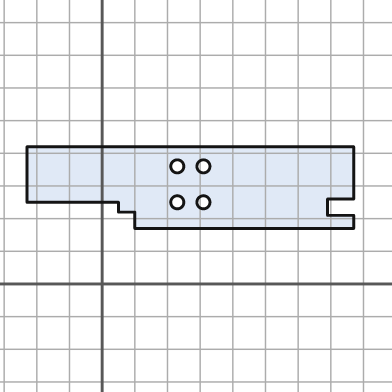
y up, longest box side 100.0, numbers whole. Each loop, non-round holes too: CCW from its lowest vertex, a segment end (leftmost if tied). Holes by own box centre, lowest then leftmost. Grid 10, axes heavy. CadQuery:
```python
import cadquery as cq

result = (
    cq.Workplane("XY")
    .moveTo(10.0, 17.0)
    .lineTo(77.0, 17.0)
    .lineTo(77.0, 21.0)
    .lineTo(69.0, 21.0)
    .lineTo(69.0, 26.0)
    .lineTo(77.0, 26.0)
    .lineTo(77.0, 42.0)
    .lineTo(-23.0, 42.0)
    .lineTo(-23.0, 25.0)
    .lineTo(5.0, 25.0)
    .lineTo(5.0, 22.0)
    .lineTo(10.0, 22.0)
    .close()
    .moveTo(23.0, 25.0)
    .circle(2.0)
    .moveTo(31.0, 25.0)
    .circle(2.0)
    .moveTo(23.0, 36.0)
    .circle(2.0)
    .moveTo(31.0, 36.0)
    .circle(2.0)
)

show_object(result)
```